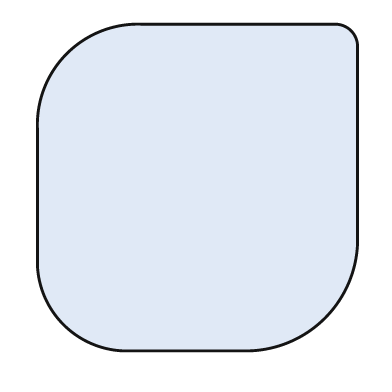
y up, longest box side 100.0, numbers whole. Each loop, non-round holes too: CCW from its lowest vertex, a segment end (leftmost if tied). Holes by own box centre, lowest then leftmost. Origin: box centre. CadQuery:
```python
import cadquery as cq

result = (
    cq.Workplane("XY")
    .moveTo(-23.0, -50.0)
    .lineTo(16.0, -50.0)
    .threePointArc((39.0, -40.0), (49.0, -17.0))
    .lineTo(49.0, 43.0)
    .threePointArc((47.0, 48.0), (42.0, 50.0))
    .lineTo(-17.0, 50.0)
    .threePointArc((-40.0, 41.0), (-49.0, 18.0))
    .lineTo(-49.0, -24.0)
    .threePointArc((-41.0, -42.0), (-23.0, -50.0))
    .close()
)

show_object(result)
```